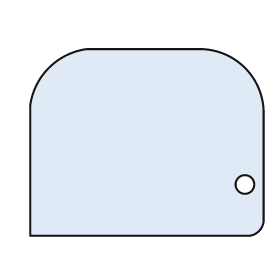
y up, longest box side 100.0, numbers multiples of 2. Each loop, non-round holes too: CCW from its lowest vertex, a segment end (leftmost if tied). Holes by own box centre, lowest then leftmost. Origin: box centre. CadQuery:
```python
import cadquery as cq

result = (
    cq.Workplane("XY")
    .moveTo(-50.0, -40.0)
    .lineTo(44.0, -40.0)
    .threePointArc((48.0, -38.0), (50.0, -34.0))
    .lineTo(50.0, 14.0)
    .threePointArc((42.0, 32.0), (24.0, 40.0))
    .lineTo(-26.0, 40.0)
    .threePointArc((-42.0, 32.0), (-50.0, 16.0))
    .close()
    .moveTo(42.0, -18.0)
    .circle(4.0)
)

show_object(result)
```